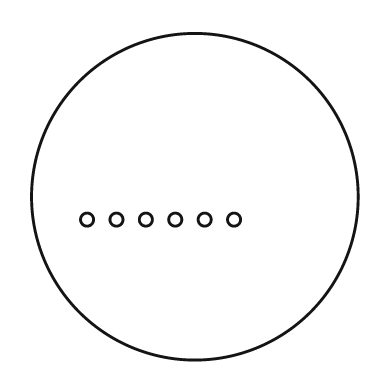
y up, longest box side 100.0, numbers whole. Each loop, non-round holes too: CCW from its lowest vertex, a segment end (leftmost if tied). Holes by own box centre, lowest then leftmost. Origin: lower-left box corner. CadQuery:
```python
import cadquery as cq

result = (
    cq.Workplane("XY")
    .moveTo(50.0, 50.0)
    .circle(50.0)
    .moveTo(17.0, 43.0)
    .circle(2.0)
    .moveTo(26.0, 43.0)
    .circle(2.0)
    .moveTo(35.0, 43.0)
    .circle(2.0)
    .moveTo(44.0, 43.0)
    .circle(2.0)
    .moveTo(53.0, 43.0)
    .circle(2.0)
    .moveTo(62.0, 43.0)
    .circle(2.0)
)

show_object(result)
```